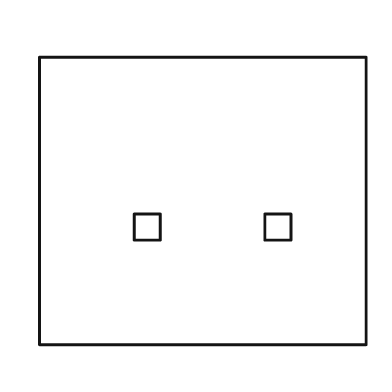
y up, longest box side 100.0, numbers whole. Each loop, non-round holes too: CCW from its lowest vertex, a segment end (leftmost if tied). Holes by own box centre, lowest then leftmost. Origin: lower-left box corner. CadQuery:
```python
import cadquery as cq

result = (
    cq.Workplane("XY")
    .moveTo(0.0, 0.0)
    .lineTo(100.0, 0.0)
    .lineTo(100.0, 88.0)
    .lineTo(0.0, 88.0)
    .close()
    .moveTo(29.0, 32.0)
    .lineTo(37.0, 32.0)
    .lineTo(37.0, 40.0)
    .lineTo(29.0, 40.0)
    .close()
    .moveTo(69.0, 32.0)
    .lineTo(77.0, 32.0)
    .lineTo(77.0, 40.0)
    .lineTo(69.0, 40.0)
    .close()
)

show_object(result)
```